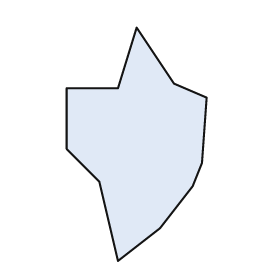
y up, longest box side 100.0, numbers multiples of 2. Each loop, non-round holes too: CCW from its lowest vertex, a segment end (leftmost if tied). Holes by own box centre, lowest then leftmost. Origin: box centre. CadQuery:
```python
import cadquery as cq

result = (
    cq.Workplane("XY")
    .moveTo(-8.0, -50.0)
    .lineTo(10.0, -36.0)
    .lineTo(24.0, -18.0)
    .lineTo(28.0, -8.0)
    .lineTo(30.0, 20.0)
    .lineTo(16.0, 26.0)
    .lineTo(0.0, 50.0)
    .lineTo(-8.0, 24.0)
    .lineTo(-30.0, 24.0)
    .lineTo(-30.0, -2.0)
    .lineTo(-16.0, -16.0)
    .close()
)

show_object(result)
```